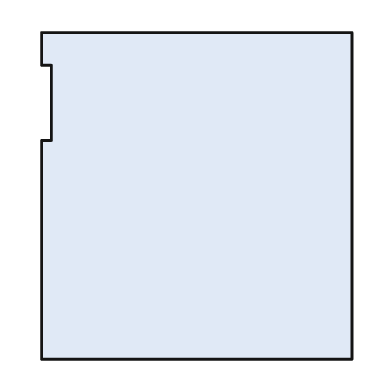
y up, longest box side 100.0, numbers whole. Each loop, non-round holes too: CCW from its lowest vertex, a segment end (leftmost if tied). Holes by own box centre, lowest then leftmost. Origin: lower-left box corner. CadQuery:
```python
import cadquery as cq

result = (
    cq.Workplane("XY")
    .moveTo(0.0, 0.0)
    .lineTo(95.0, 0.0)
    .lineTo(95.0, 100.0)
    .lineTo(0.0, 100.0)
    .lineTo(0.0, 90.0)
    .lineTo(3.0, 90.0)
    .lineTo(3.0, 67.0)
    .lineTo(0.0, 67.0)
    .close()
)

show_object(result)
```